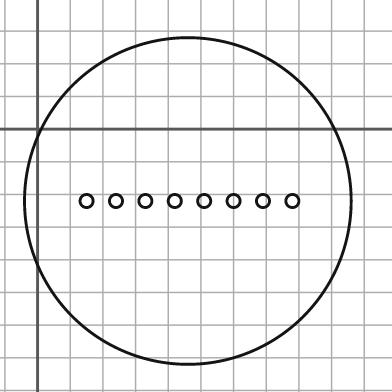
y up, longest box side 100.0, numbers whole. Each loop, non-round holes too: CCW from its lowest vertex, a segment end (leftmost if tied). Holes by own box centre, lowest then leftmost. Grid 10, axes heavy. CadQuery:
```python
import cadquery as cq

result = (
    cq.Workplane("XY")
    .moveTo(46.0, -22.0)
    .circle(50.0)
    .moveTo(15.0, -22.0)
    .circle(2.0)
    .moveTo(24.0, -22.0)
    .circle(2.0)
    .moveTo(33.0, -22.0)
    .circle(2.0)
    .moveTo(42.0, -22.0)
    .circle(2.0)
    .moveTo(51.0, -22.0)
    .circle(2.0)
    .moveTo(60.0, -22.0)
    .circle(2.0)
    .moveTo(69.0, -22.0)
    .circle(2.0)
    .moveTo(78.0, -22.0)
    .circle(2.0)
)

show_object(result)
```